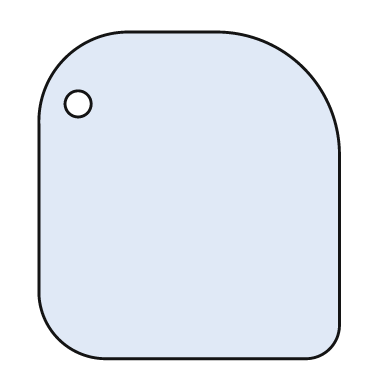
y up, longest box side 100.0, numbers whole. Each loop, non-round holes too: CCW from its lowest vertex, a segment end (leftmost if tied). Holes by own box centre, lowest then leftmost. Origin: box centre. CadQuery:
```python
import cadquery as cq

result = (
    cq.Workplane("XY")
    .moveTo(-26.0, -50.0)
    .lineTo(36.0, -50.0)
    .threePointArc((43.0, -47.0), (46.0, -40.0))
    .lineTo(46.0, 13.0)
    .threePointArc((35.0, 39.0), (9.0, 50.0))
    .lineTo(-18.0, 50.0)
    .threePointArc((-38.0, 42.0), (-46.0, 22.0))
    .lineTo(-46.0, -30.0)
    .threePointArc((-40.0, -44.0), (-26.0, -50.0))
    .close()
    .moveTo(-34.0, 28.0)
    .circle(4.0)
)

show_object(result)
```